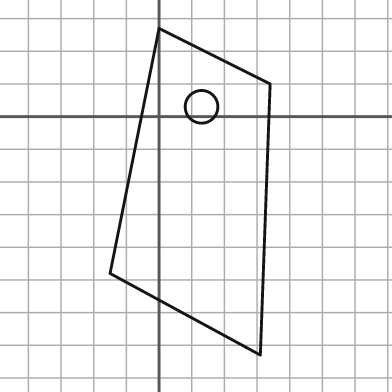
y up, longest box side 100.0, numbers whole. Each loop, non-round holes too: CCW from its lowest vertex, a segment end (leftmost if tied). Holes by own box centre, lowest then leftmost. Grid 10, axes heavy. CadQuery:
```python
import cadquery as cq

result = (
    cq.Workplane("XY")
    .moveTo(31.0, -73.0)
    .lineTo(34.0, 10.0)
    .lineTo(0.0, 27.0)
    .lineTo(-15.0, -48.0)
    .close()
    .moveTo(13.0, 3.0)
    .circle(5.0)
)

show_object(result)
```